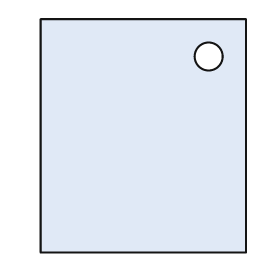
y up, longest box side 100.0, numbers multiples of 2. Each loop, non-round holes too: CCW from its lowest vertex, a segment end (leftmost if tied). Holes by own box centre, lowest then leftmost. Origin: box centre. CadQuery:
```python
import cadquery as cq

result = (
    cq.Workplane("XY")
    .moveTo(-44.0, -50.0)
    .lineTo(44.0, -50.0)
    .lineTo(44.0, 50.0)
    .lineTo(-44.0, 50.0)
    .close()
    .moveTo(28.0, 34.0)
    .circle(6.0)
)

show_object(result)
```